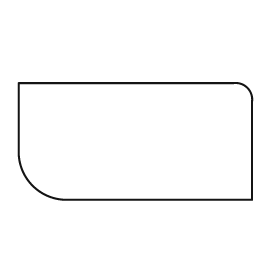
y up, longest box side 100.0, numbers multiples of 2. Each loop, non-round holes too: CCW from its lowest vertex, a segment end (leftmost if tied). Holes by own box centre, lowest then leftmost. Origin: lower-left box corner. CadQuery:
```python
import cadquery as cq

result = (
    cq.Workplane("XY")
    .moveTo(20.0, 0.0)
    .lineTo(100.0, 0.0)
    .lineTo(100.0, 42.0)
    .threePointArc((98.0, 48.0), (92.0, 50.0))
    .lineTo(0.0, 50.0)
    .lineTo(0.0, 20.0)
    .threePointArc((6.0, 6.0), (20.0, 0.0))
    .close()
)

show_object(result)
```